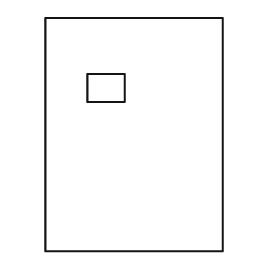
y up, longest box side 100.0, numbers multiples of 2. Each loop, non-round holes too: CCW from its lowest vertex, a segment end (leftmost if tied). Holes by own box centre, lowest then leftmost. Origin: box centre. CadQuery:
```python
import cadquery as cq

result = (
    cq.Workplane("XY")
    .moveTo(-38.0, -50.0)
    .lineTo(38.0, -50.0)
    .lineTo(38.0, 50.0)
    .lineTo(-38.0, 50.0)
    .close()
    .moveTo(-20.0, 14.0)
    .lineTo(-4.0, 14.0)
    .lineTo(-4.0, 26.0)
    .lineTo(-20.0, 26.0)
    .close()
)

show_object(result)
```